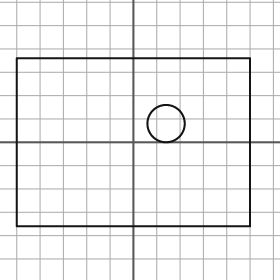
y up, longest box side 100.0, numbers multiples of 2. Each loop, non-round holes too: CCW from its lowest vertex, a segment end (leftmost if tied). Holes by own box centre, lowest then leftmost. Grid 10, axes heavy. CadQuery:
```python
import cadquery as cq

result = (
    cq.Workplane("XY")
    .moveTo(-50.0, -36.0)
    .lineTo(50.0, -36.0)
    .lineTo(50.0, 36.0)
    .lineTo(-50.0, 36.0)
    .close()
    .moveTo(14.0, 8.0)
    .circle(8.0)
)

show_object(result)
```